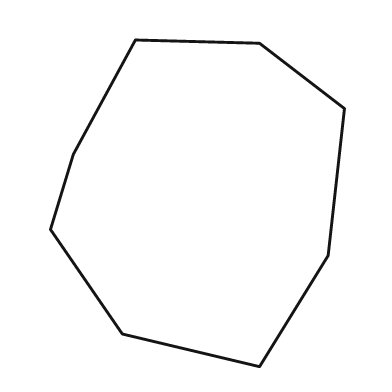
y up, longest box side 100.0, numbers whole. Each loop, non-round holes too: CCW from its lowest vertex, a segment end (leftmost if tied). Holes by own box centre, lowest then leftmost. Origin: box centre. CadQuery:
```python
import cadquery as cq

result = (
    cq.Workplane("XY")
    .moveTo(19.0, -50.0)
    .lineTo(40.0, -16.0)
    .lineTo(45.0, 29.0)
    .lineTo(19.0, 49.0)
    .lineTo(-19.0, 50.0)
    .lineTo(-38.0, 15.0)
    .lineTo(-45.0, -8.0)
    .lineTo(-23.0, -40.0)
    .close()
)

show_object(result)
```